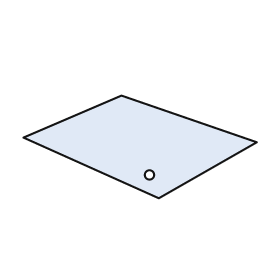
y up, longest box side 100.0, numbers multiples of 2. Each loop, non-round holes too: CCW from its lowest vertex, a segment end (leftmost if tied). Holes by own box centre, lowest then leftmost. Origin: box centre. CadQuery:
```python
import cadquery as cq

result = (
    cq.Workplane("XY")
    .moveTo(8.0, -22.0)
    .lineTo(50.0, 2.0)
    .lineTo(-8.0, 22.0)
    .lineTo(-50.0, 4.0)
    .close()
    .moveTo(4.0, -12.0)
    .circle(2.0)
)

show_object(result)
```